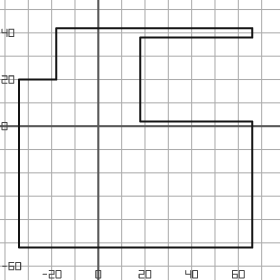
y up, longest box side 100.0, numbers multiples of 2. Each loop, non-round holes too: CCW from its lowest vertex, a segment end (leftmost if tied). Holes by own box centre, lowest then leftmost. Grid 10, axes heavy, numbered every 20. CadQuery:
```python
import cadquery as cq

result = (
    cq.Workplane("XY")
    .moveTo(-34.0, -52.0)
    .lineTo(66.0, -52.0)
    .lineTo(66.0, 2.0)
    .lineTo(18.0, 2.0)
    .lineTo(18.0, 38.0)
    .lineTo(66.0, 38.0)
    .lineTo(66.0, 42.0)
    .lineTo(-18.0, 42.0)
    .lineTo(-18.0, 20.0)
    .lineTo(-34.0, 20.0)
    .close()
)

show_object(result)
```